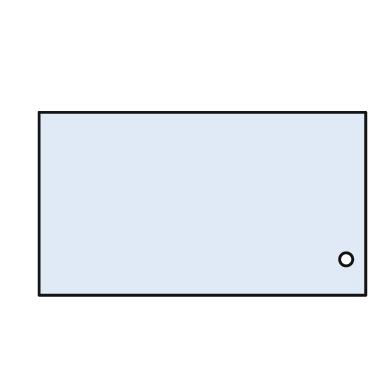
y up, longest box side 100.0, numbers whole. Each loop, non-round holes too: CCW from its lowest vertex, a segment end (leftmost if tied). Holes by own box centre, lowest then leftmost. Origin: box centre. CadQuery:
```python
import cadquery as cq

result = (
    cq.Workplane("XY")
    .moveTo(-50.0, -28.0)
    .lineTo(50.0, -28.0)
    .lineTo(50.0, 28.0)
    .lineTo(-50.0, 28.0)
    .close()
    .moveTo(44.0, -17.0)
    .circle(2.0)
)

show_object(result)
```